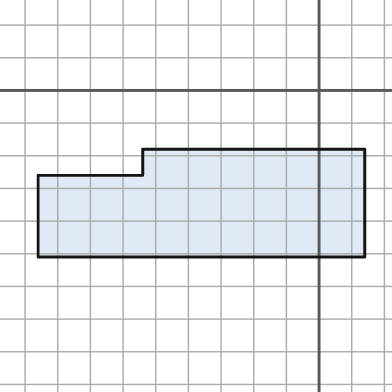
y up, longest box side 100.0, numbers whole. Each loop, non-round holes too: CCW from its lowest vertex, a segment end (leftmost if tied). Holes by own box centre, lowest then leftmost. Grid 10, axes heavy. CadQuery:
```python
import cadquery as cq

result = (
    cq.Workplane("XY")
    .moveTo(-86.0, -51.0)
    .lineTo(14.0, -51.0)
    .lineTo(14.0, -18.0)
    .lineTo(-54.0, -18.0)
    .lineTo(-54.0, -26.0)
    .lineTo(-86.0, -26.0)
    .close()
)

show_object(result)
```